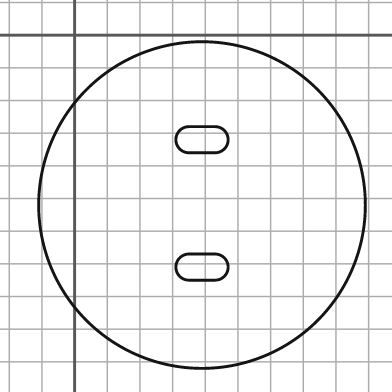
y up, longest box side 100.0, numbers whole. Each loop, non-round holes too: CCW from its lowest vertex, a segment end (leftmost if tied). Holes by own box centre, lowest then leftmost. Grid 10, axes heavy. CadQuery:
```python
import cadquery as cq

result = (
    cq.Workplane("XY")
    .moveTo(39.0, -52.0)
    .circle(50.0)
    .moveTo(35.0, -75.0)
    .lineTo(43.0, -75.0)
    .threePointArc((47.0, -71.0), (43.0, -67.0))
    .lineTo(35.0, -67.0)
    .threePointArc((31.0, -71.0), (35.0, -75.0))
    .close()
    .moveTo(35.0, -36.0)
    .lineTo(43.0, -36.0)
    .threePointArc((47.0, -32.0), (43.0, -28.0))
    .lineTo(35.0, -28.0)
    .threePointArc((31.0, -32.0), (35.0, -36.0))
    .close()
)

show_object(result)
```